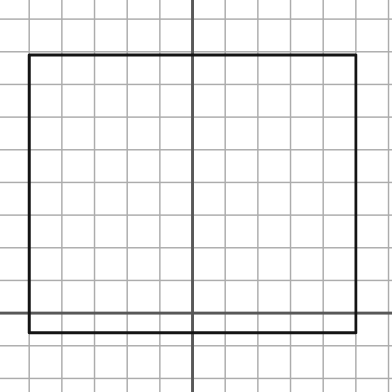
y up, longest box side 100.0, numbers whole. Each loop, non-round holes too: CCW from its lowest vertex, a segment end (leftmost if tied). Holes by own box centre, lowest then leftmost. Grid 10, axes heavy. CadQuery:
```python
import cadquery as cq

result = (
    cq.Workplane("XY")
    .moveTo(-50.0, -6.0)
    .lineTo(50.0, -6.0)
    .lineTo(50.0, 79.0)
    .lineTo(-50.0, 79.0)
    .close()
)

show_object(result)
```